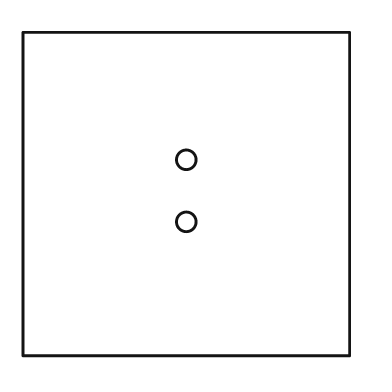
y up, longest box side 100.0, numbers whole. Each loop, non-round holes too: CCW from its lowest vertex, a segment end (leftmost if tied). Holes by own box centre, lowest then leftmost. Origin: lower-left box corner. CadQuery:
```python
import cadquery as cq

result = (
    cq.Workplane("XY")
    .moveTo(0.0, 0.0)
    .lineTo(100.0, 0.0)
    .lineTo(100.0, 99.0)
    .lineTo(0.0, 99.0)
    .close()
    .moveTo(50.0, 41.0)
    .circle(3.0)
    .moveTo(50.0, 60.0)
    .circle(3.0)
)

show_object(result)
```